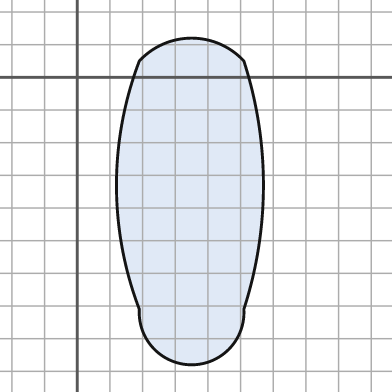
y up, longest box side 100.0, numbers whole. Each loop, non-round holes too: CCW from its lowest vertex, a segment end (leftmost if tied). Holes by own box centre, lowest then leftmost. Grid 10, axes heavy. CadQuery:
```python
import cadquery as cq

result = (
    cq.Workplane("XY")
    .moveTo(19.0, -71.0)
    .threePointArc((35.0, -88.0), (51.0, -71.0))
    .threePointArc((57.0, -33.0), (51.0, 5.0))
    .threePointArc((35.0, 12.0), (19.0, 5.0))
    .threePointArc((12.0, -33.0), (19.0, -71.0))
    .close()
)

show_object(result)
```